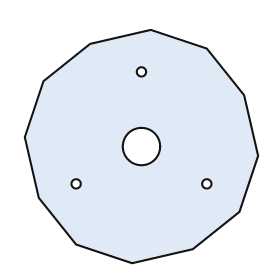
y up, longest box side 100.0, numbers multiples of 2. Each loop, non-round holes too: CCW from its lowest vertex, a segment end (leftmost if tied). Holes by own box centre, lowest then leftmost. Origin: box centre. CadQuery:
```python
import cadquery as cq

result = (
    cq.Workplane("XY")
    .moveTo(-4.0, -50.0)
    .lineTo(22.0, -44.0)
    .lineTo(42.0, -28.0)
    .lineTo(50.0, -4.0)
    .lineTo(44.0, 22.0)
    .lineTo(28.0, 42.0)
    .lineTo(4.0, 50.0)
    .lineTo(-22.0, 44.0)
    .lineTo(-42.0, 28.0)
    .lineTo(-50.0, 4.0)
    .lineTo(-44.0, -22.0)
    .lineTo(-28.0, -42.0)
    .close()
    .moveTo(-28.0, -16.0)
    .circle(2.0)
    .moveTo(28.0, -16.0)
    .circle(2.0)
    .moveTo(0.0, 0.0)
    .circle(8.0)
    .moveTo(0.0, 32.0)
    .circle(2.0)
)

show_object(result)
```